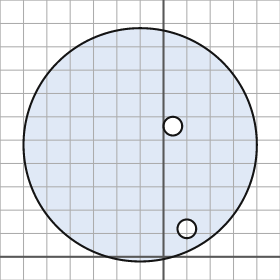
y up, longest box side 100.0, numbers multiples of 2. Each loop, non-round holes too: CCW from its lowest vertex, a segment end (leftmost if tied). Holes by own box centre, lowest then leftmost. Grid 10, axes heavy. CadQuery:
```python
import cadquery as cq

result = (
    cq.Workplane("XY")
    .moveTo(-10.0, 48.0)
    .circle(50.0)
    .moveTo(10.0, 12.0)
    .circle(4.0)
    .moveTo(4.0, 56.0)
    .circle(4.0)
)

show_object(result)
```